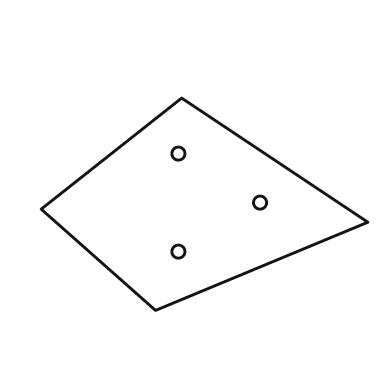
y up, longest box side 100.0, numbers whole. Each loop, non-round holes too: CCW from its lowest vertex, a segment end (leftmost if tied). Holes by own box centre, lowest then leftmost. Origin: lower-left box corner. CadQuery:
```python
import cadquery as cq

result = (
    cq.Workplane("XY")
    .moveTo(35.0, 0.0)
    .lineTo(100.0, 27.0)
    .lineTo(43.0, 65.0)
    .lineTo(0.0, 31.0)
    .close()
    .moveTo(42.0, 18.0)
    .circle(2.0)
    .moveTo(67.0, 33.0)
    .circle(2.0)
    .moveTo(42.0, 48.0)
    .circle(2.0)
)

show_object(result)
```